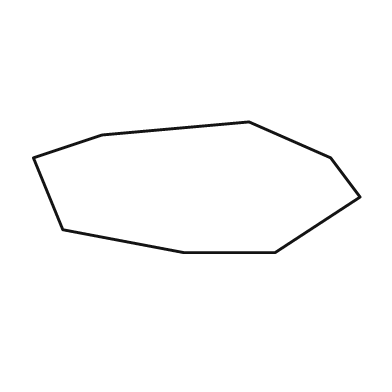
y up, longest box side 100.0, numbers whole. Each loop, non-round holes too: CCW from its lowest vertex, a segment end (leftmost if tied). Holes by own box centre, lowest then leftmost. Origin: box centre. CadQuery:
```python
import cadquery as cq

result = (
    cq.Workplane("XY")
    .moveTo(-4.0, -20.0)
    .lineTo(24.0, -20.0)
    .lineTo(50.0, -3.0)
    .lineTo(41.0, 9.0)
    .lineTo(16.0, 20.0)
    .lineTo(-29.0, 16.0)
    .lineTo(-50.0, 9.0)
    .lineTo(-41.0, -13.0)
    .close()
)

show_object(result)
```